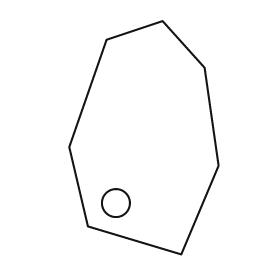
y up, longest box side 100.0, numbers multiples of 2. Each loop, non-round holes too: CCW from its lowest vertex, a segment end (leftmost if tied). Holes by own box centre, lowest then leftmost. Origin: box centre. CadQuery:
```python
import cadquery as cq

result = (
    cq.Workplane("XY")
    .moveTo(16.0, -50.0)
    .lineTo(32.0, -12.0)
    .lineTo(26.0, 30.0)
    .lineTo(8.0, 50.0)
    .lineTo(-16.0, 42.0)
    .lineTo(-32.0, -4.0)
    .lineTo(-24.0, -38.0)
    .close()
    .moveTo(-12.0, -28.0)
    .circle(6.0)
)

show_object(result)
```